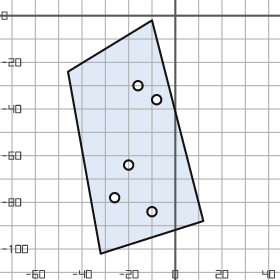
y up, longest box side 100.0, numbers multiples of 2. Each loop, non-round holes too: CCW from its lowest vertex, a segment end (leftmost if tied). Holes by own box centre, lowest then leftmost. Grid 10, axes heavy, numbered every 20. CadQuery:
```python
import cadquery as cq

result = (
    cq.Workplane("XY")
    .moveTo(-32.0, -102.0)
    .lineTo(12.0, -88.0)
    .lineTo(-10.0, -2.0)
    .lineTo(-46.0, -24.0)
    .close()
    .moveTo(-10.0, -84.0)
    .circle(2.0)
    .moveTo(-26.0, -78.0)
    .circle(2.0)
    .moveTo(-20.0, -64.0)
    .circle(2.0)
    .moveTo(-8.0, -36.0)
    .circle(2.0)
    .moveTo(-16.0, -30.0)
    .circle(2.0)
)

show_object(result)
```